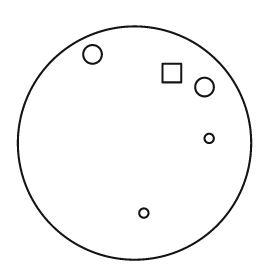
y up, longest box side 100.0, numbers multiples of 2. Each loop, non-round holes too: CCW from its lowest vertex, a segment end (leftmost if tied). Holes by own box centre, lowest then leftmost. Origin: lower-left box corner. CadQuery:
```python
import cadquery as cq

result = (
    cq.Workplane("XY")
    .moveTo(50.0, 50.0)
    .circle(50.0)
    .moveTo(54.0, 20.0)
    .circle(2.0)
    .moveTo(82.0, 52.0)
    .circle(2.0)
    .moveTo(80.0, 74.0)
    .circle(4.0)
    .moveTo(62.0, 76.0)
    .lineTo(70.0, 76.0)
    .lineTo(70.0, 84.0)
    .lineTo(62.0, 84.0)
    .close()
    .moveTo(32.0, 88.0)
    .circle(4.0)
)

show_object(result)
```